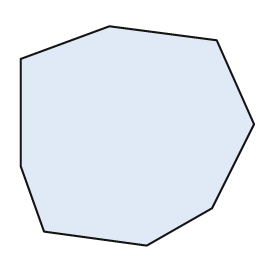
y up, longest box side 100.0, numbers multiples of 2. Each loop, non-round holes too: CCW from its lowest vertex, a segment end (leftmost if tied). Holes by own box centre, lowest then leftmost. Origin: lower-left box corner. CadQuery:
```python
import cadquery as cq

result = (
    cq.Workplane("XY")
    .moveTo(54.0, 0.0)
    .lineTo(82.0, 16.0)
    .lineTo(100.0, 52.0)
    .lineTo(84.0, 88.0)
    .lineTo(38.0, 94.0)
    .lineTo(0.0, 80.0)
    .lineTo(0.0, 34.0)
    .lineTo(10.0, 6.0)
    .close()
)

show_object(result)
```